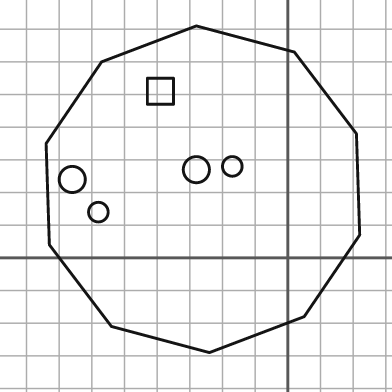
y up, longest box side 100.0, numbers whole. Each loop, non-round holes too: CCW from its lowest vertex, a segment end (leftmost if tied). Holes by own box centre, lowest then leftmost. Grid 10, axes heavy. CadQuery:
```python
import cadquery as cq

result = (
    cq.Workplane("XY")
    .moveTo(-24.0, -29.0)
    .lineTo(5.0, -18.0)
    .lineTo(22.0, 7.0)
    .lineTo(21.0, 38.0)
    .lineTo(2.0, 63.0)
    .lineTo(-28.0, 71.0)
    .lineTo(-57.0, 60.0)
    .lineTo(-74.0, 35.0)
    .lineTo(-73.0, 4.0)
    .lineTo(-54.0, -21.0)
    .close()
    .moveTo(-58.0, 14.0)
    .circle(3.0)
    .moveTo(-66.0, 24.0)
    .circle(4.0)
    .moveTo(-28.0, 27.0)
    .circle(4.0)
    .moveTo(-17.0, 28.0)
    .circle(3.0)
    .moveTo(-43.0, 47.0)
    .lineTo(-35.0, 47.0)
    .lineTo(-35.0, 55.0)
    .lineTo(-43.0, 55.0)
    .close()
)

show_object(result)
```